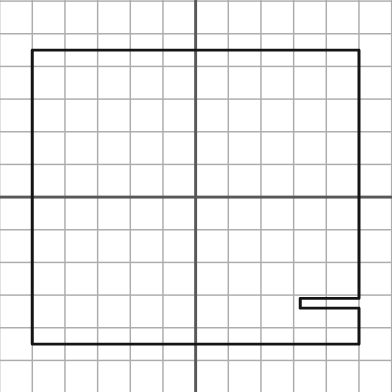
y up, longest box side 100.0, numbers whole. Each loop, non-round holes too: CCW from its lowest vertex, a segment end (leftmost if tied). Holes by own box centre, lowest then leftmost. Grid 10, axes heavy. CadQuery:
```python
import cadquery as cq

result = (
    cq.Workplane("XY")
    .moveTo(-50.0, -45.0)
    .lineTo(50.0, -45.0)
    .lineTo(50.0, -34.0)
    .lineTo(32.0, -34.0)
    .lineTo(32.0, -31.0)
    .lineTo(50.0, -31.0)
    .lineTo(50.0, 45.0)
    .lineTo(-50.0, 45.0)
    .close()
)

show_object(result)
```